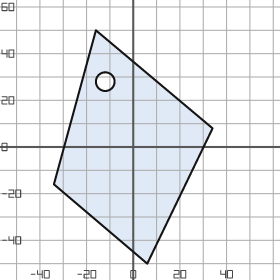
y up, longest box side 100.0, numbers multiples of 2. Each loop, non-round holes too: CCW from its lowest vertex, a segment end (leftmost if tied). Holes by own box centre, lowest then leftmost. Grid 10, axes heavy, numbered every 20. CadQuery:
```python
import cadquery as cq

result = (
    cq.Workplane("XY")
    .moveTo(6.0, -50.0)
    .lineTo(34.0, 8.0)
    .lineTo(-16.0, 50.0)
    .lineTo(-34.0, -16.0)
    .close()
    .moveTo(-12.0, 28.0)
    .circle(4.0)
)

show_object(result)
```